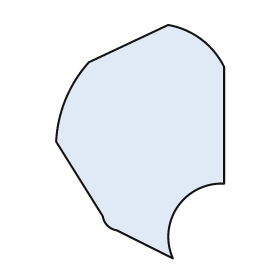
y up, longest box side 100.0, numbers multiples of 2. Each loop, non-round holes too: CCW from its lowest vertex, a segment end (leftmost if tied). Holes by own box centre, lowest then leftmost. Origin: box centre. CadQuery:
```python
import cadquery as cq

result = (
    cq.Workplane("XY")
    .moveTo(14.0, -50.0)
    .threePointArc((16.0, -28.0), (36.0, -18.0))
    .lineTo(36.0, 32.0)
    .threePointArc((26.0, 44.0), (12.0, 50.0))
    .lineTo(-22.0, 34.0)
    .threePointArc((-32.0, 18.0), (-36.0, 0.0))
    .lineTo(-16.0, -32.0)
    .threePointArc((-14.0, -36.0), (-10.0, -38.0))
    .close()
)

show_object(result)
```